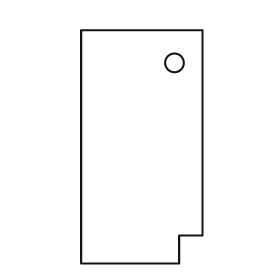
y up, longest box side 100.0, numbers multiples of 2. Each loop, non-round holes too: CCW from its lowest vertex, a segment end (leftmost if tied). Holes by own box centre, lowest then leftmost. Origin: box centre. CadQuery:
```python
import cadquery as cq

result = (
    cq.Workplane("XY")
    .moveTo(-26.0, -50.0)
    .lineTo(16.0, -50.0)
    .lineTo(16.0, -38.0)
    .lineTo(26.0, -38.0)
    .lineTo(26.0, 50.0)
    .lineTo(-26.0, 50.0)
    .close()
    .moveTo(14.0, 36.0)
    .circle(4.0)
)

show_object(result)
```